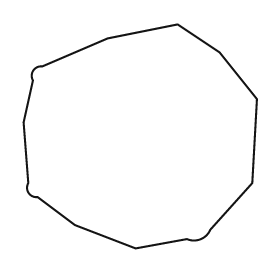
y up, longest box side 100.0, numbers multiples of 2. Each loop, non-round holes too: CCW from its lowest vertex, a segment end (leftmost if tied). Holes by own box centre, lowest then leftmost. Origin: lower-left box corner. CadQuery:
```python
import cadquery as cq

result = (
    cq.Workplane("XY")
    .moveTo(48.0, 0.0)
    .lineTo(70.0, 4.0)
    .threePointArc((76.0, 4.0), (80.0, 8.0))
    .lineTo(98.0, 28.0)
    .lineTo(100.0, 64.0)
    .lineTo(84.0, 84.0)
    .lineTo(66.0, 96.0)
    .lineTo(36.0, 90.0)
    .lineTo(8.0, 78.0)
    .threePointArc((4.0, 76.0), (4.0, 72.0))
    .lineTo(0.0, 54.0)
    .lineTo(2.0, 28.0)
    .threePointArc((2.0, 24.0), (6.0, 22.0))
    .lineTo(22.0, 10.0)
    .close()
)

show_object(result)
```